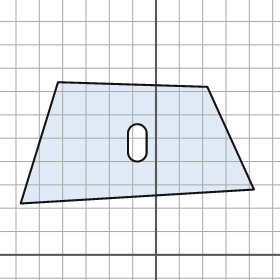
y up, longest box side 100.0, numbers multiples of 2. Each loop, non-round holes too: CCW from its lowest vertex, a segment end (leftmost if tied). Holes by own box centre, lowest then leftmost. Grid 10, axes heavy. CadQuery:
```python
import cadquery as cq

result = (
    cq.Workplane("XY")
    .moveTo(-58.0, 22.0)
    .lineTo(42.0, 28.0)
    .lineTo(22.0, 72.0)
    .lineTo(-42.0, 74.0)
    .close()
    .moveTo(-12.0, 44.0)
    .threePointArc((-8.0, 40.0), (-4.0, 44.0))
    .lineTo(-4.0, 52.0)
    .threePointArc((-8.0, 56.0), (-12.0, 52.0))
    .close()
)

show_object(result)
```